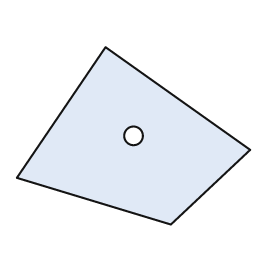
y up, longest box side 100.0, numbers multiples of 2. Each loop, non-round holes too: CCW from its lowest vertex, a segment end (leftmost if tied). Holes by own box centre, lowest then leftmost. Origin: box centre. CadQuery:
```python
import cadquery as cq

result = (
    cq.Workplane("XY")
    .moveTo(16.0, -38.0)
    .lineTo(50.0, -6.0)
    .lineTo(-12.0, 38.0)
    .lineTo(-50.0, -18.0)
    .close()
    .moveTo(0.0, 0.0)
    .circle(4.0)
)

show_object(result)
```